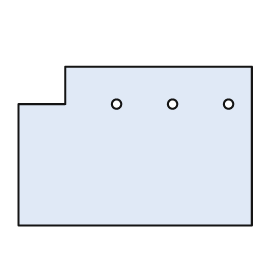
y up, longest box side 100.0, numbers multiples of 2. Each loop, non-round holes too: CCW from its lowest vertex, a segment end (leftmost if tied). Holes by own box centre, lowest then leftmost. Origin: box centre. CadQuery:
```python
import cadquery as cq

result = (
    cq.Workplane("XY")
    .moveTo(-50.0, -34.0)
    .lineTo(50.0, -34.0)
    .lineTo(50.0, 34.0)
    .lineTo(-30.0, 34.0)
    .lineTo(-30.0, 18.0)
    .lineTo(-50.0, 18.0)
    .close()
    .moveTo(-8.0, 18.0)
    .circle(2.0)
    .moveTo(16.0, 18.0)
    .circle(2.0)
    .moveTo(40.0, 18.0)
    .circle(2.0)
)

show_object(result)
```